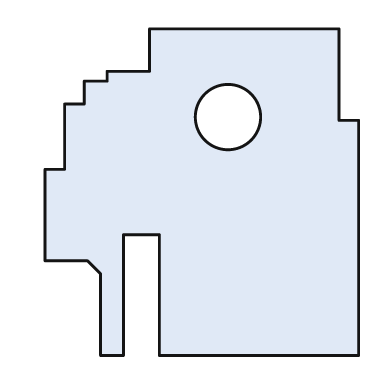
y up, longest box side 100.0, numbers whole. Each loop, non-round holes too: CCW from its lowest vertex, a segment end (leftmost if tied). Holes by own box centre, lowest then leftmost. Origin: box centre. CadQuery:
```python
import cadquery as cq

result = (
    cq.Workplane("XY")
    .moveTo(-31.0, -50.0)
    .lineTo(-24.0, -50.0)
    .lineTo(-24.0, -13.0)
    .lineTo(-13.0, -13.0)
    .lineTo(-13.0, -50.0)
    .lineTo(48.0, -50.0)
    .lineTo(48.0, 22.0)
    .lineTo(42.0, 22.0)
    .lineTo(42.0, 50.0)
    .lineTo(-16.0, 50.0)
    .lineTo(-16.0, 37.0)
    .lineTo(-29.0, 37.0)
    .lineTo(-29.0, 34.0)
    .lineTo(-36.0, 34.0)
    .lineTo(-36.0, 27.0)
    .lineTo(-42.0, 27.0)
    .lineTo(-42.0, 7.0)
    .lineTo(-48.0, 7.0)
    .lineTo(-48.0, -21.0)
    .lineTo(-35.0, -21.0)
    .lineTo(-31.0, -25.0)
    .close()
    .moveTo(8.0, 23.0)
    .circle(10.0)
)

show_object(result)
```